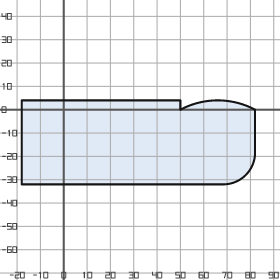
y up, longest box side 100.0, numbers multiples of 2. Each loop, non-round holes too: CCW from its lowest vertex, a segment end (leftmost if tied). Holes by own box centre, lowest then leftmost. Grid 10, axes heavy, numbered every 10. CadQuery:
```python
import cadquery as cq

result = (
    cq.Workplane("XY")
    .moveTo(-18.0, -32.0)
    .lineTo(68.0, -32.0)
    .threePointArc((78.0, -28.0), (82.0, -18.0))
    .lineTo(82.0, 0.0)
    .threePointArc((66.0, 4.0), (50.0, 0.0))
    .lineTo(50.0, 4.0)
    .lineTo(-18.0, 4.0)
    .close()
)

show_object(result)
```